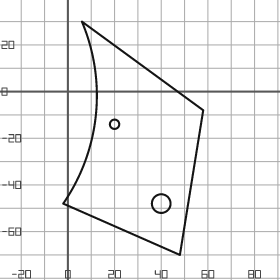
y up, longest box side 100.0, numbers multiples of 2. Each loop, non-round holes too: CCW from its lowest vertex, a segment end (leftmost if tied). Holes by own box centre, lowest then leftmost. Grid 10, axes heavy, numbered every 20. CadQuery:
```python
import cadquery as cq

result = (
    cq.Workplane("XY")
    .moveTo(48.0, -70.0)
    .lineTo(58.0, -8.0)
    .lineTo(6.0, 30.0)
    .threePointArc((12.0, -10.0), (-2.0, -48.0))
    .close()
    .moveTo(40.0, -48.0)
    .circle(4.0)
    .moveTo(20.0, -14.0)
    .circle(2.0)
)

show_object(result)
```